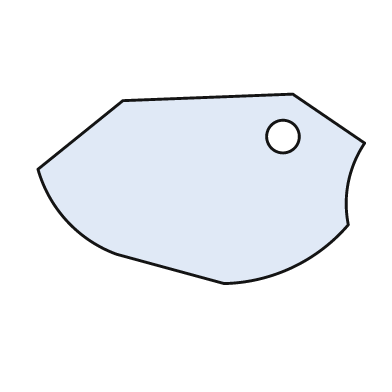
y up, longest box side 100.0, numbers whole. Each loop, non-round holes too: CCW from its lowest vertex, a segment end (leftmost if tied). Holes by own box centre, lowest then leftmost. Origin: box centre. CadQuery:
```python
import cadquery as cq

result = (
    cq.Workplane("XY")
    .moveTo(7.0, -29.0)
    .threePointArc((28.0, -24.0), (45.0, -11.0))
    .threePointArc((45.0, 2.0), (50.0, 14.0))
    .lineTo(28.0, 29.0)
    .lineTo(-24.0, 27.0)
    .lineTo(-50.0, 6.0)
    .threePointArc((-41.0, -10.0), (-26.0, -20.0))
    .close()
    .moveTo(25.0, 16.0)
    .circle(5.0)
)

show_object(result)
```